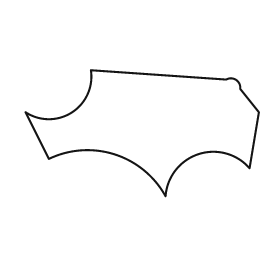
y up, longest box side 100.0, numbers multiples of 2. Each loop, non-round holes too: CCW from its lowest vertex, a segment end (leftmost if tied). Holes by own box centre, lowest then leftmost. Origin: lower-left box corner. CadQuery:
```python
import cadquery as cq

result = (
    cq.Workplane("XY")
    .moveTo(60.0, 0.0)
    .threePointArc((74.0, 18.0), (96.0, 12.0))
    .lineTo(100.0, 36.0)
    .lineTo(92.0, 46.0)
    .threePointArc((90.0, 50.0), (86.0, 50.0))
    .lineTo(28.0, 54.0)
    .threePointArc((20.0, 36.0), (0.0, 36.0))
    .lineTo(10.0, 16.0)
    .threePointArc((38.0, 18.0), (60.0, 0.0))
    .close()
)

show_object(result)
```